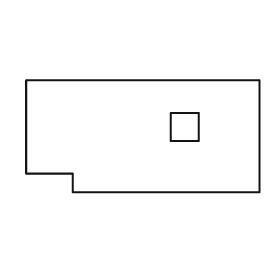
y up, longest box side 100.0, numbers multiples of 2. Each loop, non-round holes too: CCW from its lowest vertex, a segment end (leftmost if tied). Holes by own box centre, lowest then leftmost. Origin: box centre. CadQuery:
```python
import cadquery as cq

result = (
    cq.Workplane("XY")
    .moveTo(-30.0, -24.0)
    .lineTo(50.0, -24.0)
    .lineTo(50.0, 24.0)
    .lineTo(-50.0, 24.0)
    .lineTo(-50.0, -16.0)
    .lineTo(-30.0, -16.0)
    .close()
    .moveTo(12.0, -2.0)
    .lineTo(24.0, -2.0)
    .lineTo(24.0, 10.0)
    .lineTo(12.0, 10.0)
    .close()
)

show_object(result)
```